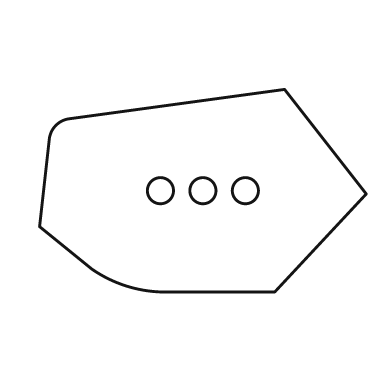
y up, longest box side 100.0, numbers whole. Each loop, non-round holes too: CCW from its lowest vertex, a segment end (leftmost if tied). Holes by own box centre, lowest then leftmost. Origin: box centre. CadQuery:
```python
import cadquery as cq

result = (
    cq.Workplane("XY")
    .moveTo(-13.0, -31.0)
    .lineTo(22.0, -31.0)
    .lineTo(50.0, -1.0)
    .lineTo(25.0, 31.0)
    .lineTo(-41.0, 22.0)
    .threePointArc((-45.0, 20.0), (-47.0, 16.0))
    .lineTo(-50.0, -11.0)
    .lineTo(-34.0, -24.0)
    .threePointArc((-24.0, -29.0), (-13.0, -31.0))
    .close()
    .moveTo(-13.0, 0.0)
    .circle(4.0)
    .moveTo(0.0, 0.0)
    .circle(4.0)
    .moveTo(13.0, 0.0)
    .circle(4.0)
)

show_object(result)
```